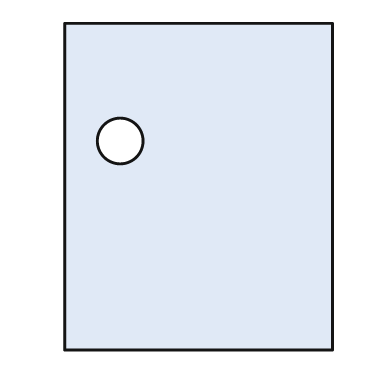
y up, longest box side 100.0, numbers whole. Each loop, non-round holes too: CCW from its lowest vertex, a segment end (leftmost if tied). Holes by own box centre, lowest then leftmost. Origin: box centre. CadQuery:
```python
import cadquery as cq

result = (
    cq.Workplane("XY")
    .moveTo(-41.0, -50.0)
    .lineTo(41.0, -50.0)
    .lineTo(41.0, 50.0)
    .lineTo(-41.0, 50.0)
    .close()
    .moveTo(-24.0, 14.0)
    .circle(7.0)
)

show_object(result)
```